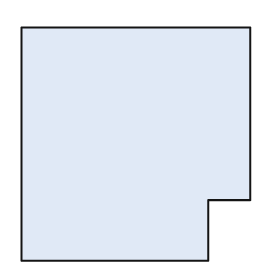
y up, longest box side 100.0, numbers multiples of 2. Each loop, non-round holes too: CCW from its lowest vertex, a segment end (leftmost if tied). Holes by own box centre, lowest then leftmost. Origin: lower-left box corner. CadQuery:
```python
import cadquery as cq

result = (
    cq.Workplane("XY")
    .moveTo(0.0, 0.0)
    .lineTo(80.0, 0.0)
    .lineTo(80.0, 26.0)
    .lineTo(98.0, 26.0)
    .lineTo(98.0, 100.0)
    .lineTo(0.0, 100.0)
    .close()
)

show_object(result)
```